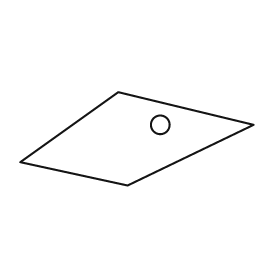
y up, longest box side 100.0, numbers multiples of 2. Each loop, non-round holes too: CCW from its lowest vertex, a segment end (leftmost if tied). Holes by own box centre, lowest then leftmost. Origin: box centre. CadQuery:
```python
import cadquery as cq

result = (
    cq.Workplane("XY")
    .moveTo(-4.0, -20.0)
    .lineTo(50.0, 6.0)
    .lineTo(-8.0, 20.0)
    .lineTo(-50.0, -10.0)
    .close()
    .moveTo(10.0, 6.0)
    .circle(4.0)
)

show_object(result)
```